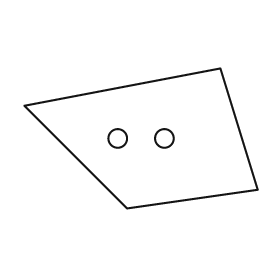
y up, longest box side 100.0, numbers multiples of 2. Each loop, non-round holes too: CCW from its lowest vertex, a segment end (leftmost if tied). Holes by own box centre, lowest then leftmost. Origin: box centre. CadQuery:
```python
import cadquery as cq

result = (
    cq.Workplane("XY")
    .moveTo(-6.0, -30.0)
    .lineTo(50.0, -22.0)
    .lineTo(34.0, 30.0)
    .lineTo(-50.0, 14.0)
    .close()
    .moveTo(-10.0, 0.0)
    .circle(4.0)
    .moveTo(10.0, 0.0)
    .circle(4.0)
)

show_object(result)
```